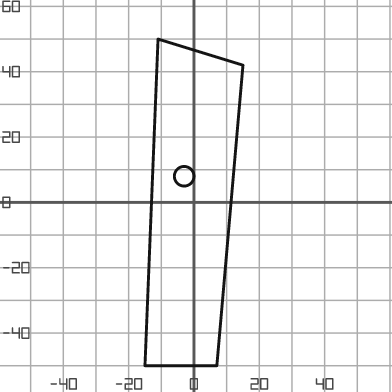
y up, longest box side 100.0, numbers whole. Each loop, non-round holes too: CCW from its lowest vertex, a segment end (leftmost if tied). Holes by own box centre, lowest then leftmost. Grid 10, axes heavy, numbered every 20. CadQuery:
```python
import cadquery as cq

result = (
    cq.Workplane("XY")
    .moveTo(-15.0, -50.0)
    .lineTo(7.0, -50.0)
    .lineTo(15.0, 42.0)
    .lineTo(-11.0, 50.0)
    .close()
    .moveTo(-3.0, 8.0)
    .circle(3.0)
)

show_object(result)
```